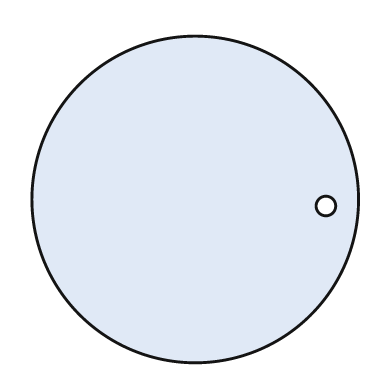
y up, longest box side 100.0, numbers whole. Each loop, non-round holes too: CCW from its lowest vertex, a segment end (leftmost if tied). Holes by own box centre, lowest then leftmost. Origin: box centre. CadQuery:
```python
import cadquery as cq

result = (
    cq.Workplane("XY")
    .moveTo(0.0, 0.0)
    .circle(50.0)
    .moveTo(40.0, -2.0)
    .circle(3.0)
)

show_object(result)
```